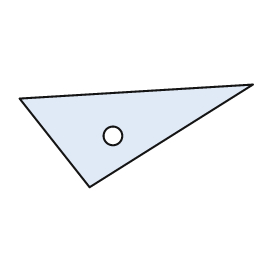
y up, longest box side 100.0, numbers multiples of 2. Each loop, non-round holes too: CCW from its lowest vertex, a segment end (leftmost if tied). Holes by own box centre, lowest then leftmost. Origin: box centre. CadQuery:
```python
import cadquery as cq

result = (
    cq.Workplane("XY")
    .moveTo(-20.0, -22.0)
    .lineTo(50.0, 22.0)
    .lineTo(-50.0, 16.0)
    .close()
    .moveTo(-10.0, 0.0)
    .circle(4.0)
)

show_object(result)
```